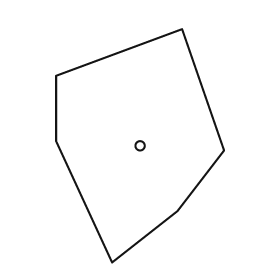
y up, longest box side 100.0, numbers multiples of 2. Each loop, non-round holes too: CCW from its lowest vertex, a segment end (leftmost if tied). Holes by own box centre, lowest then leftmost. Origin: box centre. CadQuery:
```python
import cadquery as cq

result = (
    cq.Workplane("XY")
    .moveTo(-12.0, -50.0)
    .lineTo(16.0, -28.0)
    .lineTo(36.0, -2.0)
    .lineTo(18.0, 50.0)
    .lineTo(-36.0, 30.0)
    .lineTo(-36.0, 2.0)
    .close()
    .moveTo(0.0, 0.0)
    .circle(2.0)
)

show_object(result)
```